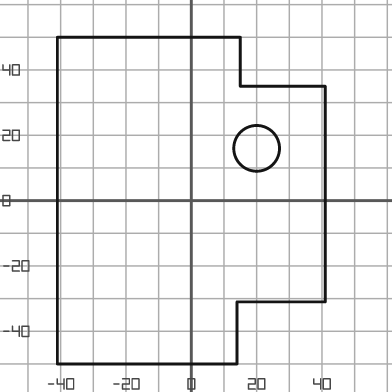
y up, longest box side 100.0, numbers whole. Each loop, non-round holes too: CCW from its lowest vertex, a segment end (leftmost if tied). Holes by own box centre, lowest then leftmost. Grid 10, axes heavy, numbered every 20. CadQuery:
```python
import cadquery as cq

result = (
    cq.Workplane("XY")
    .moveTo(-41.0, -50.0)
    .lineTo(14.0, -50.0)
    .lineTo(14.0, -31.0)
    .lineTo(41.0, -31.0)
    .lineTo(41.0, 35.0)
    .lineTo(15.0, 35.0)
    .lineTo(15.0, 50.0)
    .lineTo(-41.0, 50.0)
    .close()
    .moveTo(20.0, 16.0)
    .circle(7.0)
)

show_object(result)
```